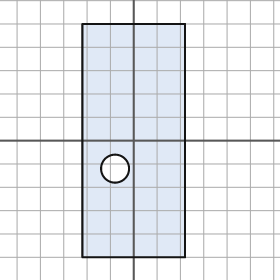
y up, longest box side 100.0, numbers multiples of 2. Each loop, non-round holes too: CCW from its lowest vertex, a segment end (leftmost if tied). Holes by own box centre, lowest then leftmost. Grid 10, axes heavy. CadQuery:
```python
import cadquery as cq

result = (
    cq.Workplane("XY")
    .moveTo(-22.0, -50.0)
    .lineTo(22.0, -50.0)
    .lineTo(22.0, 50.0)
    .lineTo(-22.0, 50.0)
    .close()
    .moveTo(-8.0, -12.0)
    .circle(6.0)
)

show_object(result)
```